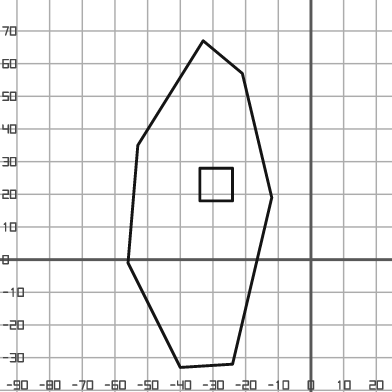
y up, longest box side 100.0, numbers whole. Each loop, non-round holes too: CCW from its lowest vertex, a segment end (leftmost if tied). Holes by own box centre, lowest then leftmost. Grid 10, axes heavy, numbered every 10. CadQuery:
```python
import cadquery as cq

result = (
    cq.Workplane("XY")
    .moveTo(-40.0, -33.0)
    .lineTo(-24.0, -32.0)
    .lineTo(-12.0, 19.0)
    .lineTo(-21.0, 57.0)
    .lineTo(-33.0, 67.0)
    .lineTo(-53.0, 35.0)
    .lineTo(-56.0, -1.0)
    .close()
    .moveTo(-34.0, 18.0)
    .lineTo(-24.0, 18.0)
    .lineTo(-24.0, 28.0)
    .lineTo(-34.0, 28.0)
    .close()
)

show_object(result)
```